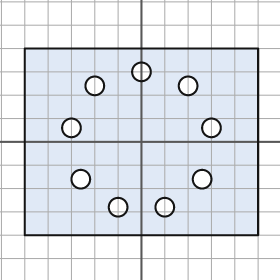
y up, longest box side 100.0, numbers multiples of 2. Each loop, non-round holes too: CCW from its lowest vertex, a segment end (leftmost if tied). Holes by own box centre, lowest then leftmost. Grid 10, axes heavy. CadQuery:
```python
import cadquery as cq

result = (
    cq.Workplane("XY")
    .moveTo(-50.0, -40.0)
    .lineTo(50.0, -40.0)
    .lineTo(50.0, 40.0)
    .lineTo(-50.0, 40.0)
    .close()
    .moveTo(-10.0, -28.0)
    .circle(4.0)
    .moveTo(10.0, -28.0)
    .circle(4.0)
    .moveTo(-26.0, -16.0)
    .circle(4.0)
    .moveTo(26.0, -16.0)
    .circle(4.0)
    .moveTo(-30.0, 6.0)
    .circle(4.0)
    .moveTo(30.0, 6.0)
    .circle(4.0)
    .moveTo(-20.0, 24.0)
    .circle(4.0)
    .moveTo(20.0, 24.0)
    .circle(4.0)
    .moveTo(0.0, 30.0)
    .circle(4.0)
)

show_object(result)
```